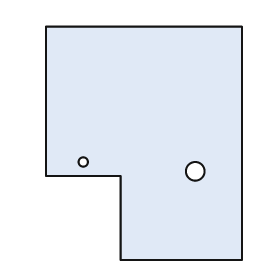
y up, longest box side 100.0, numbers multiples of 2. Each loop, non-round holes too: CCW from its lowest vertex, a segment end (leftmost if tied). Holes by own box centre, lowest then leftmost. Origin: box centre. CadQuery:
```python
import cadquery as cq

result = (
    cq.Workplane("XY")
    .moveTo(-10.0, -50.0)
    .lineTo(42.0, -50.0)
    .lineTo(42.0, 50.0)
    .lineTo(-42.0, 50.0)
    .lineTo(-42.0, -14.0)
    .lineTo(-10.0, -14.0)
    .close()
    .moveTo(22.0, -12.0)
    .circle(4.0)
    .moveTo(-26.0, -8.0)
    .circle(2.0)
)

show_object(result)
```